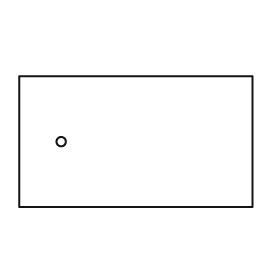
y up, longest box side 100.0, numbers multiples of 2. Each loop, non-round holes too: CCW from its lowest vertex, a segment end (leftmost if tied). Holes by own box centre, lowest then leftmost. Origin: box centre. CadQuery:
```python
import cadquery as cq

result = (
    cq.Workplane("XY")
    .moveTo(-50.0, -28.0)
    .lineTo(50.0, -28.0)
    .lineTo(50.0, 28.0)
    .lineTo(-50.0, 28.0)
    .close()
    .moveTo(-32.0, 0.0)
    .circle(2.0)
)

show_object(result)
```